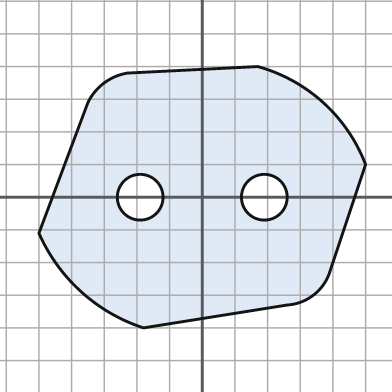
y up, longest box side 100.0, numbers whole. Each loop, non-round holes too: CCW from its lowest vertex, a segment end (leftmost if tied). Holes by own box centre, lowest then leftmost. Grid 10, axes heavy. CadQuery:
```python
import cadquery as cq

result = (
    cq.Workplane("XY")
    .moveTo(-18.0, -40.0)
    .lineTo(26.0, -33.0)
    .threePointArc((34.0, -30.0), (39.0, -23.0))
    .lineTo(50.0, 10.0)
    .threePointArc((37.0, 29.0), (17.0, 40.0))
    .lineTo(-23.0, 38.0)
    .threePointArc((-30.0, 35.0), (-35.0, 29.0))
    .lineTo(-50.0, -11.0)
    .threePointArc((-37.0, -29.0), (-18.0, -40.0))
    .close()
    .moveTo(-19.0, 0.0)
    .circle(7.0)
    .moveTo(19.0, 0.0)
    .circle(7.0)
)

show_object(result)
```